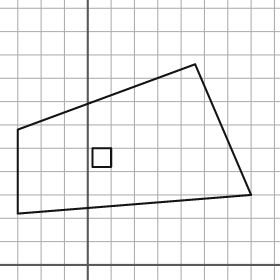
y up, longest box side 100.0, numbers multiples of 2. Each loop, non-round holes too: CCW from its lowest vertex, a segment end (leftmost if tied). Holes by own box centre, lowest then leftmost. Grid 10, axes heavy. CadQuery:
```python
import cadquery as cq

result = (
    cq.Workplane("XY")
    .moveTo(-30.0, 22.0)
    .lineTo(70.0, 30.0)
    .lineTo(46.0, 86.0)
    .lineTo(-30.0, 58.0)
    .close()
    .moveTo(2.0, 42.0)
    .lineTo(10.0, 42.0)
    .lineTo(10.0, 50.0)
    .lineTo(2.0, 50.0)
    .close()
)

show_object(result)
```